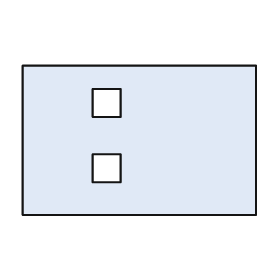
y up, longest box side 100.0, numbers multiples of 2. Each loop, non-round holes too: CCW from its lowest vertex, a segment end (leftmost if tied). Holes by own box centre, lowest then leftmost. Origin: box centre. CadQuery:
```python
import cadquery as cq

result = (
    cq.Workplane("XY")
    .moveTo(-50.0, -32.0)
    .lineTo(50.0, -32.0)
    .lineTo(50.0, 32.0)
    .lineTo(-50.0, 32.0)
    .close()
    .moveTo(-20.0, -18.0)
    .lineTo(-8.0, -18.0)
    .lineTo(-8.0, -6.0)
    .lineTo(-20.0, -6.0)
    .close()
    .moveTo(-20.0, 10.0)
    .lineTo(-8.0, 10.0)
    .lineTo(-8.0, 22.0)
    .lineTo(-20.0, 22.0)
    .close()
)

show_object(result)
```